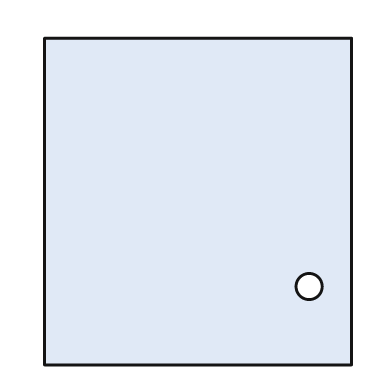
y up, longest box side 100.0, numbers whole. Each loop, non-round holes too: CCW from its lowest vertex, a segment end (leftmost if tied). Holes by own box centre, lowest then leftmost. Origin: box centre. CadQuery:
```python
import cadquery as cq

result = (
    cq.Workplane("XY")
    .moveTo(-47.0, -50.0)
    .lineTo(47.0, -50.0)
    .lineTo(47.0, 50.0)
    .lineTo(-47.0, 50.0)
    .close()
    .moveTo(34.0, -26.0)
    .circle(4.0)
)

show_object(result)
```